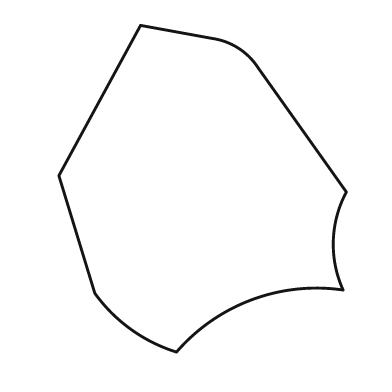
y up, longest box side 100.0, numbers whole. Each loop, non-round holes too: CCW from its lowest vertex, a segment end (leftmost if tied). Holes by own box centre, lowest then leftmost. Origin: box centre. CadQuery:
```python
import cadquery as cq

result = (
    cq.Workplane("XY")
    .moveTo(-8.0, -50.0)
    .threePointArc((15.0, -34.0), (43.0, -31.0))
    .threePointArc((40.0, -16.0), (44.0, -1.0))
    .lineTo(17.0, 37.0)
    .threePointArc((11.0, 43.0), (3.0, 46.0))
    .lineTo(-19.0, 50.0)
    .lineTo(-44.0, 4.0)
    .lineTo(-33.0, -32.0)
    .threePointArc((-22.0, -43.0), (-8.0, -50.0))
    .close()
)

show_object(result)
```